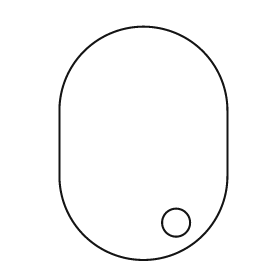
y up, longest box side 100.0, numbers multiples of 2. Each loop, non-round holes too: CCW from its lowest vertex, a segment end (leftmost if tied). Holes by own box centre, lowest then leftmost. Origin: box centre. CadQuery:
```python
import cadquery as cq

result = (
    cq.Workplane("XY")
    .moveTo(-36.0, -14.0)
    .threePointArc((0.0, -50.0), (36.0, -14.0))
    .lineTo(36.0, 14.0)
    .threePointArc((0.0, 50.0), (-36.0, 14.0))
    .close()
    .moveTo(14.0, -34.0)
    .circle(6.0)
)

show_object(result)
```